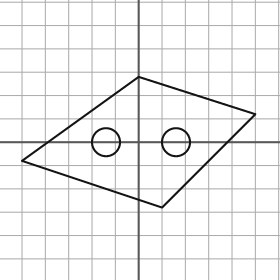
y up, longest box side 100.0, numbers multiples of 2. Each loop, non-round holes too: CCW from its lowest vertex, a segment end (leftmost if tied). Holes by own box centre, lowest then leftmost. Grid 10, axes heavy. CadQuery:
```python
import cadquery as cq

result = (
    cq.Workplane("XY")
    .moveTo(10.0, -28.0)
    .lineTo(50.0, 12.0)
    .lineTo(0.0, 28.0)
    .lineTo(-50.0, -8.0)
    .close()
    .moveTo(-14.0, 0.0)
    .circle(6.0)
    .moveTo(16.0, 0.0)
    .circle(6.0)
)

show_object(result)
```